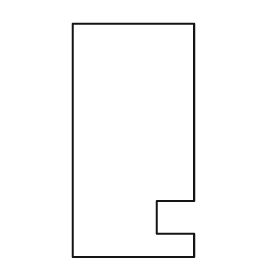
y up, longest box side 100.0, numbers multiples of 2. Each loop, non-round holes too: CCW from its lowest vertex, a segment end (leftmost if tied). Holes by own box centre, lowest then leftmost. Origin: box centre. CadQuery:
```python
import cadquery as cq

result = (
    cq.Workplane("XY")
    .moveTo(-26.0, -50.0)
    .lineTo(26.0, -50.0)
    .lineTo(26.0, -40.0)
    .lineTo(10.0, -40.0)
    .lineTo(10.0, -26.0)
    .lineTo(26.0, -26.0)
    .lineTo(26.0, 50.0)
    .lineTo(-26.0, 50.0)
    .close()
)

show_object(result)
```